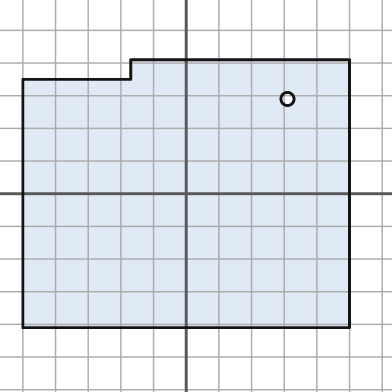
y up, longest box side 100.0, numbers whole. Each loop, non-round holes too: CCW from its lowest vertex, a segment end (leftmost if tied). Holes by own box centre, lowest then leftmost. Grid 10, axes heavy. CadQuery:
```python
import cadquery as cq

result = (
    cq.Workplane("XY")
    .moveTo(-50.0, -41.0)
    .lineTo(50.0, -41.0)
    .lineTo(50.0, 41.0)
    .lineTo(-17.0, 41.0)
    .lineTo(-17.0, 35.0)
    .lineTo(-50.0, 35.0)
    .close()
    .moveTo(31.0, 29.0)
    .circle(2.0)
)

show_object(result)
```